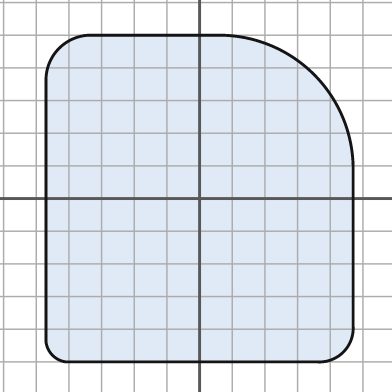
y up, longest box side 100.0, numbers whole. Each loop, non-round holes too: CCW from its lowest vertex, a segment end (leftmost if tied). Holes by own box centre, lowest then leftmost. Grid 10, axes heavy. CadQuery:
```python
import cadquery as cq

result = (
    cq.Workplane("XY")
    .moveTo(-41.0, -50.0)
    .lineTo(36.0, -50.0)
    .threePointArc((44.0, -47.0), (47.0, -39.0))
    .lineTo(47.0, 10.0)
    .threePointArc((35.0, 38.0), (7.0, 50.0))
    .lineTo(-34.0, 50.0)
    .threePointArc((-43.0, 46.0), (-47.0, 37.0))
    .lineTo(-47.0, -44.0)
    .threePointArc((-45.0, -48.0), (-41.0, -50.0))
    .close()
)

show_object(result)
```